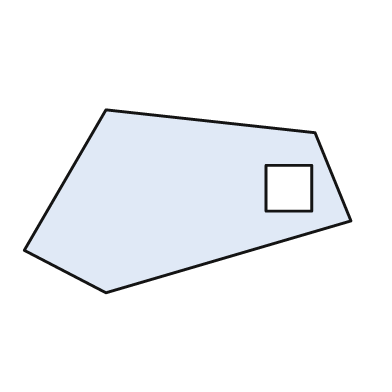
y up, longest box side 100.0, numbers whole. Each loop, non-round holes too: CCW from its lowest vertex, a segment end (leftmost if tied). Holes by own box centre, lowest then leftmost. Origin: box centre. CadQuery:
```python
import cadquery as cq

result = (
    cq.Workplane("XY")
    .moveTo(-25.0, -28.0)
    .lineTo(50.0, -6.0)
    .lineTo(39.0, 21.0)
    .lineTo(-25.0, 28.0)
    .lineTo(-50.0, -15.0)
    .close()
    .moveTo(24.0, -3.0)
    .lineTo(38.0, -3.0)
    .lineTo(38.0, 11.0)
    .lineTo(24.0, 11.0)
    .close()
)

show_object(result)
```